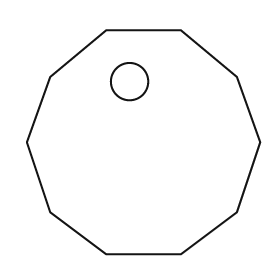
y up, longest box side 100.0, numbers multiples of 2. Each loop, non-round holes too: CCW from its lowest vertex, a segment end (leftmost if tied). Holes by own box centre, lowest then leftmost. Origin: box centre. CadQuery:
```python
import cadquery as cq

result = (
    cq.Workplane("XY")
    .moveTo(-16.0, -48.0)
    .lineTo(16.0, -48.0)
    .lineTo(40.0, -30.0)
    .lineTo(50.0, 0.0)
    .lineTo(40.0, 28.0)
    .lineTo(16.0, 48.0)
    .lineTo(-16.0, 48.0)
    .lineTo(-40.0, 28.0)
    .lineTo(-50.0, 0.0)
    .lineTo(-40.0, -30.0)
    .close()
    .moveTo(-6.0, 26.0)
    .circle(8.0)
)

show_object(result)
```